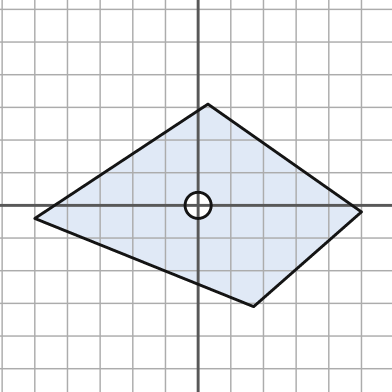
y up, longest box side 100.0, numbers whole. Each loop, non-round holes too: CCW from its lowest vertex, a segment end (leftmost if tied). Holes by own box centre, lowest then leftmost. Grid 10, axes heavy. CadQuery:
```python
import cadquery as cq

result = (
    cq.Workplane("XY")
    .moveTo(17.0, -31.0)
    .lineTo(50.0, -2.0)
    .lineTo(3.0, 31.0)
    .lineTo(-50.0, -4.0)
    .close()
    .moveTo(0.0, 0.0)
    .circle(4.0)
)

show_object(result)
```